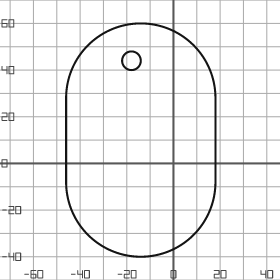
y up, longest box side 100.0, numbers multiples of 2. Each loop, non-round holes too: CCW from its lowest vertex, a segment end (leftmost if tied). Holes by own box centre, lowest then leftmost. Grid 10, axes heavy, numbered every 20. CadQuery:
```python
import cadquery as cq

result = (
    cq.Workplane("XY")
    .moveTo(-46.0, -8.0)
    .threePointArc((-14.0, -40.0), (18.0, -8.0))
    .lineTo(18.0, 28.0)
    .threePointArc((-14.0, 60.0), (-46.0, 28.0))
    .close()
    .moveTo(-18.0, 44.0)
    .circle(4.0)
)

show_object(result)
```